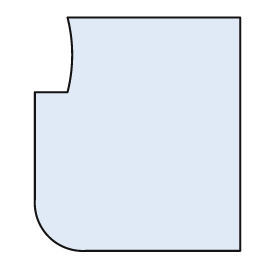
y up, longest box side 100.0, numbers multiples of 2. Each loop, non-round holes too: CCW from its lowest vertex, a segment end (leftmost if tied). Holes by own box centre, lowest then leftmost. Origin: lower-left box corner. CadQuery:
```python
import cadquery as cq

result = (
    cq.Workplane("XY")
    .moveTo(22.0, 0.0)
    .lineTo(88.0, 0.0)
    .lineTo(88.0, 100.0)
    .lineTo(14.0, 100.0)
    .threePointArc((16.0, 84.0), (14.0, 68.0))
    .lineTo(0.0, 68.0)
    .lineTo(0.0, 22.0)
    .threePointArc((6.0, 6.0), (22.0, 0.0))
    .close()
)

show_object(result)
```